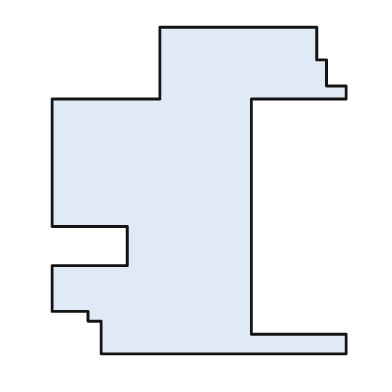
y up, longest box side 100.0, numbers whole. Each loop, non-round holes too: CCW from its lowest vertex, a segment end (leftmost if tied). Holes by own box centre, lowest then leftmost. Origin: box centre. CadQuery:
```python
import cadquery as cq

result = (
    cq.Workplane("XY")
    .moveTo(-30.0, -50.0)
    .lineTo(45.0, -50.0)
    .lineTo(45.0, -44.0)
    .lineTo(16.0, -44.0)
    .lineTo(16.0, 28.0)
    .lineTo(45.0, 28.0)
    .lineTo(45.0, 32.0)
    .lineTo(39.0, 32.0)
    .lineTo(39.0, 40.0)
    .lineTo(36.0, 40.0)
    .lineTo(36.0, 50.0)
    .lineTo(-12.0, 50.0)
    .lineTo(-12.0, 28.0)
    .lineTo(-45.0, 28.0)
    .lineTo(-45.0, -11.0)
    .lineTo(-22.0, -11.0)
    .lineTo(-22.0, -23.0)
    .lineTo(-45.0, -23.0)
    .lineTo(-45.0, -37.0)
    .lineTo(-34.0, -37.0)
    .lineTo(-34.0, -40.0)
    .lineTo(-30.0, -40.0)
    .close()
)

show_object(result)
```